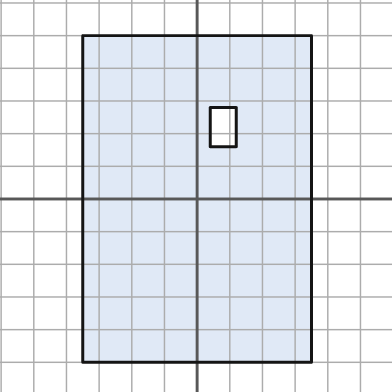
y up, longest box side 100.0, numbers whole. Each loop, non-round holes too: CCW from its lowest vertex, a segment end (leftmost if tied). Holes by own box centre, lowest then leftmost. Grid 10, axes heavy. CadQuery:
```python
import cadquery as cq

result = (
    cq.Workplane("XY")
    .moveTo(-35.0, -50.0)
    .lineTo(35.0, -50.0)
    .lineTo(35.0, 50.0)
    .lineTo(-35.0, 50.0)
    .close()
    .moveTo(4.0, 16.0)
    .lineTo(12.0, 16.0)
    .lineTo(12.0, 28.0)
    .lineTo(4.0, 28.0)
    .close()
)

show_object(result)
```